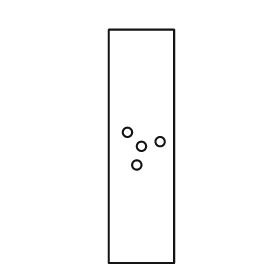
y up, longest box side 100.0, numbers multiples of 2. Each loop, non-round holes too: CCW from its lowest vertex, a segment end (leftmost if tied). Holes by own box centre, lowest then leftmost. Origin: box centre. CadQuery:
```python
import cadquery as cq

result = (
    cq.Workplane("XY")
    .moveTo(-14.0, -50.0)
    .lineTo(14.0, -50.0)
    .lineTo(14.0, 50.0)
    .lineTo(-14.0, 50.0)
    .close()
    .moveTo(-2.0, -8.0)
    .circle(2.0)
    .moveTo(0.0, 0.0)
    .circle(2.0)
    .moveTo(8.0, 2.0)
    .circle(2.0)
    .moveTo(-6.0, 6.0)
    .circle(2.0)
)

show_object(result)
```